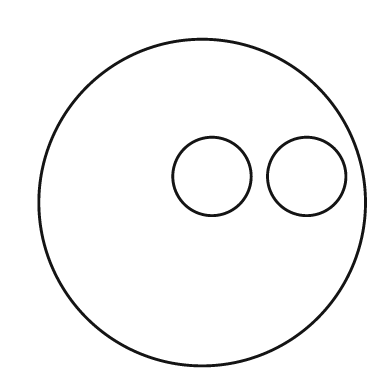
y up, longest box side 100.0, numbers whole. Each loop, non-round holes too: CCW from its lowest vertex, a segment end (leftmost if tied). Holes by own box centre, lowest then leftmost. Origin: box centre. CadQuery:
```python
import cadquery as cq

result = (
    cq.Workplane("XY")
    .moveTo(0.0, 0.0)
    .circle(50.0)
    .moveTo(3.0, 8.0)
    .circle(12.0)
    .moveTo(32.0, 8.0)
    .circle(12.0)
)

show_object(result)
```